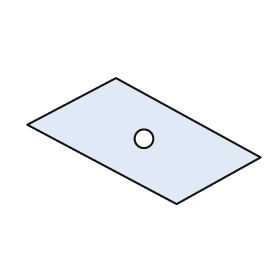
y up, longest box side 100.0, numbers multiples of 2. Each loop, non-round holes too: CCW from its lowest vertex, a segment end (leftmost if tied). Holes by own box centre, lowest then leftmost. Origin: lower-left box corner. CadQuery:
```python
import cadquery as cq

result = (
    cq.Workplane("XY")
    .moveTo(64.0, 0.0)
    .lineTo(100.0, 20.0)
    .lineTo(38.0, 54.0)
    .lineTo(0.0, 34.0)
    .close()
    .moveTo(50.0, 28.0)
    .circle(4.0)
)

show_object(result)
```